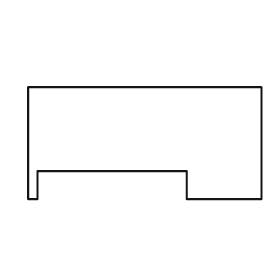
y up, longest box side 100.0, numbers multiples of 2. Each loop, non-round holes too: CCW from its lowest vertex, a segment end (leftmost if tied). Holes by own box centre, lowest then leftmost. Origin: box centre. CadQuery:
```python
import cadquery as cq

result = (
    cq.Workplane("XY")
    .moveTo(-50.0, -24.0)
    .lineTo(-46.0, -24.0)
    .lineTo(-46.0, -12.0)
    .lineTo(18.0, -12.0)
    .lineTo(18.0, -24.0)
    .lineTo(50.0, -24.0)
    .lineTo(50.0, 24.0)
    .lineTo(-50.0, 24.0)
    .close()
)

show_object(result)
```